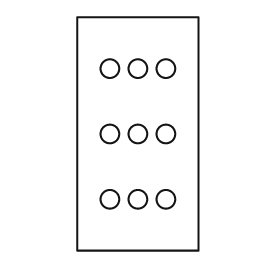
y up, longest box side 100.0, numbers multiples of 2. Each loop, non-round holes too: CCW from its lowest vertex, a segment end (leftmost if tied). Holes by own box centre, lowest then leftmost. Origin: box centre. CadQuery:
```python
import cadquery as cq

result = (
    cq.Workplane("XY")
    .moveTo(-26.0, -50.0)
    .lineTo(26.0, -50.0)
    .lineTo(26.0, 50.0)
    .lineTo(-26.0, 50.0)
    .close()
    .moveTo(-12.0, -28.0)
    .circle(4.0)
    .moveTo(0.0, -28.0)
    .circle(4.0)
    .moveTo(12.0, -28.0)
    .circle(4.0)
    .moveTo(-12.0, 0.0)
    .circle(4.0)
    .moveTo(0.0, 0.0)
    .circle(4.0)
    .moveTo(12.0, 0.0)
    .circle(4.0)
    .moveTo(-12.0, 28.0)
    .circle(4.0)
    .moveTo(0.0, 28.0)
    .circle(4.0)
    .moveTo(12.0, 28.0)
    .circle(4.0)
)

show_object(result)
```